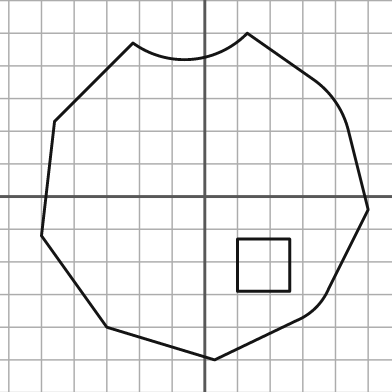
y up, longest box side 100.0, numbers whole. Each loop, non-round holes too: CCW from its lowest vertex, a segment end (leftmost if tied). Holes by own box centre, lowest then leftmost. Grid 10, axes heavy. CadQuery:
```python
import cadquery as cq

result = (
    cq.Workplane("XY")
    .moveTo(3.0, -50.0)
    .lineTo(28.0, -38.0)
    .threePointArc((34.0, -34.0), (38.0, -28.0))
    .lineTo(50.0, -4.0)
    .lineTo(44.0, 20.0)
    .threePointArc((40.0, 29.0), (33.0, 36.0))
    .lineTo(13.0, 50.0)
    .threePointArc((-4.0, 42.0), (-22.0, 47.0))
    .lineTo(-46.0, 23.0)
    .lineTo(-50.0, -12.0)
    .lineTo(-30.0, -40.0)
    .close()
    .moveTo(10.0, -29.0)
    .lineTo(26.0, -29.0)
    .lineTo(26.0, -13.0)
    .lineTo(10.0, -13.0)
    .close()
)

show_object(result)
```